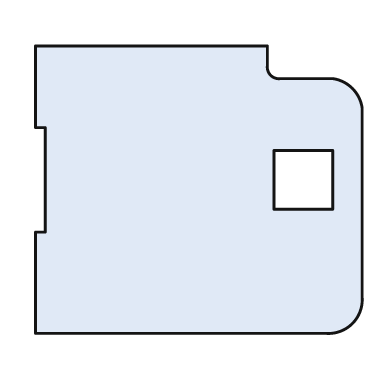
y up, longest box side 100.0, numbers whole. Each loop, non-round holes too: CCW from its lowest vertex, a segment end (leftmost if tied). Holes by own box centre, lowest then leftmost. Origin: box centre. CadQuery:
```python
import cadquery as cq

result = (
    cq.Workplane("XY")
    .moveTo(-50.0, -44.0)
    .lineTo(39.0, -44.0)
    .threePointArc((47.0, -41.0), (50.0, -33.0))
    .lineTo(50.0, 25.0)
    .threePointArc((47.0, 31.0), (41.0, 34.0))
    .lineTo(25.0, 34.0)
    .threePointArc((22.0, 35.0), (21.0, 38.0))
    .lineTo(21.0, 44.0)
    .lineTo(-50.0, 44.0)
    .lineTo(-50.0, 19.0)
    .lineTo(-47.0, 19.0)
    .lineTo(-47.0, -13.0)
    .lineTo(-50.0, -13.0)
    .close()
    .moveTo(23.0, -6.0)
    .lineTo(41.0, -6.0)
    .lineTo(41.0, 12.0)
    .lineTo(23.0, 12.0)
    .close()
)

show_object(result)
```